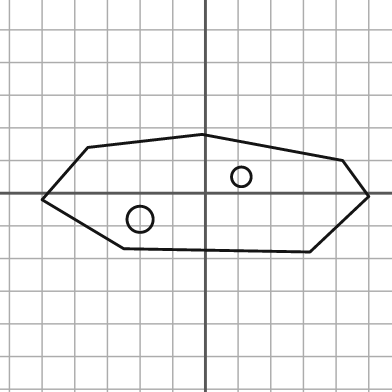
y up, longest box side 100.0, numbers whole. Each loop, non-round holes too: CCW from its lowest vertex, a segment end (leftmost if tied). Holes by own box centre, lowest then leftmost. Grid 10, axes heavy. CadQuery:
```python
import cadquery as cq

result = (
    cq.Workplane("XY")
    .moveTo(32.0, -18.0)
    .lineTo(50.0, -1.0)
    .lineTo(42.0, 10.0)
    .lineTo(-1.0, 18.0)
    .lineTo(-36.0, 14.0)
    .lineTo(-50.0, -2.0)
    .lineTo(-25.0, -17.0)
    .close()
    .moveTo(-20.0, -8.0)
    .circle(4.0)
    .moveTo(11.0, 5.0)
    .circle(3.0)
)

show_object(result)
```